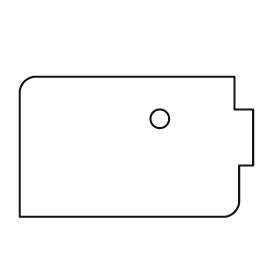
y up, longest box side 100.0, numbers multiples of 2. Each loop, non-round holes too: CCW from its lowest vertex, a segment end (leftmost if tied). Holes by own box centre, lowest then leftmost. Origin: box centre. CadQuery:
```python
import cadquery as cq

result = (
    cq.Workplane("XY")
    .moveTo(-50.0, -30.0)
    .lineTo(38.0, -30.0)
    .threePointArc((42.0, -28.0), (44.0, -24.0))
    .lineTo(44.0, -8.0)
    .lineTo(50.0, -8.0)
    .lineTo(50.0, 16.0)
    .lineTo(42.0, 16.0)
    .lineTo(42.0, 30.0)
    .lineTo(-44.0, 30.0)
    .threePointArc((-48.0, 28.0), (-50.0, 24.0))
    .close()
    .moveTo(10.0, 12.0)
    .circle(4.0)
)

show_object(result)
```